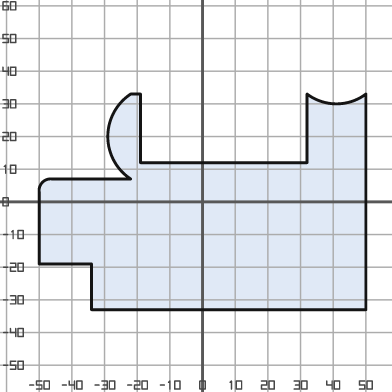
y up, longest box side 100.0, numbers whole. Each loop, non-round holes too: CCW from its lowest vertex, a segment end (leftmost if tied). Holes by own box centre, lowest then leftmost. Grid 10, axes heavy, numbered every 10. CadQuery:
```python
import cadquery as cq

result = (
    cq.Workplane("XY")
    .moveTo(-34.0, -33.0)
    .lineTo(50.0, -33.0)
    .lineTo(50.0, 33.0)
    .threePointArc((41.0, 30.0), (32.0, 33.0))
    .lineTo(32.0, 12.0)
    .lineTo(-19.0, 12.0)
    .lineTo(-19.0, 33.0)
    .lineTo(-22.0, 33.0)
    .threePointArc((-29.0, 20.0), (-22.0, 7.0))
    .lineTo(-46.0, 7.0)
    .threePointArc((-49.0, 6.0), (-50.0, 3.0))
    .lineTo(-50.0, -19.0)
    .lineTo(-34.0, -19.0)
    .close()
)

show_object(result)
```